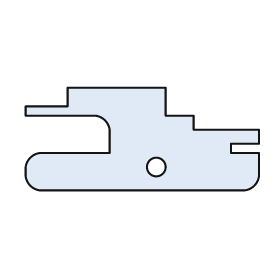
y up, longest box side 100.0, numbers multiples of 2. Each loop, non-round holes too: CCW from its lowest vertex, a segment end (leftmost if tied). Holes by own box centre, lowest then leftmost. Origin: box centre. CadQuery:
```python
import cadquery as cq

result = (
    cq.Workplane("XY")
    .moveTo(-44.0, -22.0)
    .lineTo(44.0, -22.0)
    .threePointArc((48.0, -20.0), (50.0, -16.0))
    .lineTo(50.0, -6.0)
    .lineTo(38.0, -6.0)
    .lineTo(38.0, -2.0)
    .lineTo(50.0, -2.0)
    .lineTo(50.0, 4.0)
    .lineTo(22.0, 4.0)
    .lineTo(22.0, 10.0)
    .lineTo(10.0, 10.0)
    .lineTo(10.0, 22.0)
    .lineTo(-32.0, 22.0)
    .lineTo(-32.0, 14.0)
    .lineTo(-50.0, 14.0)
    .lineTo(-50.0, 10.0)
    .lineTo(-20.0, 10.0)
    .threePointArc((-16.0, 8.0), (-14.0, 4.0))
    .lineTo(-14.0, -6.0)
    .lineTo(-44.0, -6.0)
    .threePointArc((-48.0, -8.0), (-50.0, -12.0))
    .lineTo(-50.0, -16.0)
    .threePointArc((-48.0, -20.0), (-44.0, -22.0))
    .close()
    .moveTo(6.0, -12.0)
    .circle(4.0)
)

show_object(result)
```